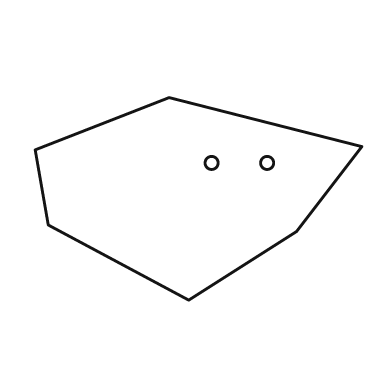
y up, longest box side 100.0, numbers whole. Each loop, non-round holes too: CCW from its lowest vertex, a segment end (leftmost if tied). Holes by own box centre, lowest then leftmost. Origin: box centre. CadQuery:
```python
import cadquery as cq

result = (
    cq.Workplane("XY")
    .moveTo(-3.0, -31.0)
    .lineTo(30.0, -10.0)
    .lineTo(50.0, 16.0)
    .lineTo(-9.0, 31.0)
    .lineTo(-50.0, 15.0)
    .lineTo(-46.0, -8.0)
    .close()
    .moveTo(4.0, 11.0)
    .circle(2.0)
    .moveTo(21.0, 11.0)
    .circle(2.0)
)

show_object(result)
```